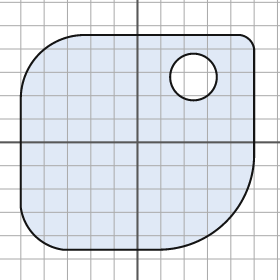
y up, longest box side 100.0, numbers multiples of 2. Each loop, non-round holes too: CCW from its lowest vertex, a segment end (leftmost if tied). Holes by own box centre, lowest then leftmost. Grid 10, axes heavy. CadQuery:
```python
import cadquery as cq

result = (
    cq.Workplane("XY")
    .moveTo(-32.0, -46.0)
    .lineTo(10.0, -46.0)
    .threePointArc((38.0, -34.0), (50.0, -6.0))
    .lineTo(50.0, 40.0)
    .threePointArc((48.0, 44.0), (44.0, 46.0))
    .lineTo(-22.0, 46.0)
    .threePointArc((-42.0, 38.0), (-50.0, 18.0))
    .lineTo(-50.0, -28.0)
    .threePointArc((-44.0, -40.0), (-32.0, -46.0))
    .close()
    .moveTo(24.0, 28.0)
    .circle(10.0)
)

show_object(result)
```